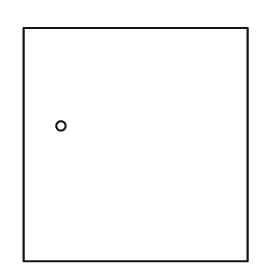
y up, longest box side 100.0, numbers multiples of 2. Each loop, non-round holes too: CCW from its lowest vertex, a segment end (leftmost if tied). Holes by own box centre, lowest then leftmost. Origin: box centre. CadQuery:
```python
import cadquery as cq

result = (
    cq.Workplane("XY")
    .moveTo(-48.0, -50.0)
    .lineTo(48.0, -50.0)
    .lineTo(48.0, 50.0)
    .lineTo(-48.0, 50.0)
    .close()
    .moveTo(-32.0, 8.0)
    .circle(2.0)
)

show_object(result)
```